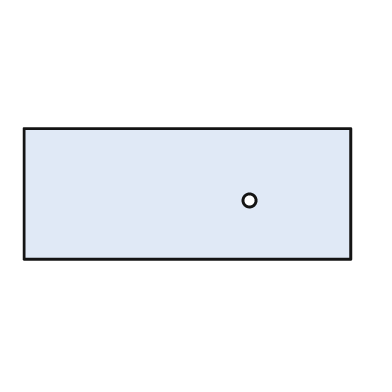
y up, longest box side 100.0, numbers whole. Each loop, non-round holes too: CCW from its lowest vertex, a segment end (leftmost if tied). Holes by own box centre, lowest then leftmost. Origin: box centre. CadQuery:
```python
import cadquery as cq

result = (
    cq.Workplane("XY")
    .moveTo(-50.0, -20.0)
    .lineTo(50.0, -20.0)
    .lineTo(50.0, 20.0)
    .lineTo(-50.0, 20.0)
    .close()
    .moveTo(19.0, -2.0)
    .circle(2.0)
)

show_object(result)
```